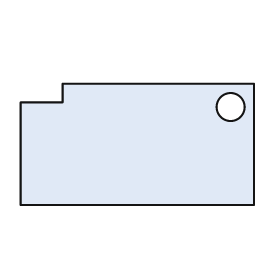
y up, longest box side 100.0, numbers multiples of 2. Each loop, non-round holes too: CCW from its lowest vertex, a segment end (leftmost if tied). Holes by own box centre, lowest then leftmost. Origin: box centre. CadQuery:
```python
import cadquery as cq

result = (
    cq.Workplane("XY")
    .moveTo(-50.0, -26.0)
    .lineTo(50.0, -26.0)
    .lineTo(50.0, 26.0)
    .lineTo(-32.0, 26.0)
    .lineTo(-32.0, 18.0)
    .lineTo(-50.0, 18.0)
    .close()
    .moveTo(40.0, 16.0)
    .circle(6.0)
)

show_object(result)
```